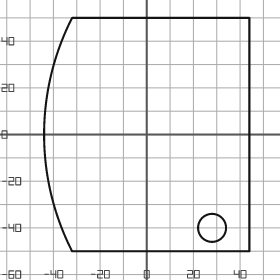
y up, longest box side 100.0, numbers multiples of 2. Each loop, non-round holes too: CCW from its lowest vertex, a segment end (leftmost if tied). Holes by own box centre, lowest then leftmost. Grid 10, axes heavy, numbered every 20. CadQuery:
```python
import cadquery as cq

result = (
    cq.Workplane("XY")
    .moveTo(-32.0, -50.0)
    .lineTo(44.0, -50.0)
    .lineTo(44.0, 50.0)
    .lineTo(-32.0, 50.0)
    .threePointArc((-44.0, 0.0), (-32.0, -50.0))
    .close()
    .moveTo(28.0, -40.0)
    .circle(6.0)
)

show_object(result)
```